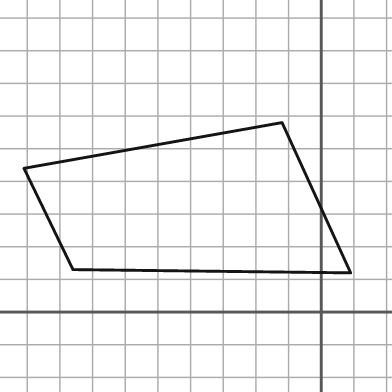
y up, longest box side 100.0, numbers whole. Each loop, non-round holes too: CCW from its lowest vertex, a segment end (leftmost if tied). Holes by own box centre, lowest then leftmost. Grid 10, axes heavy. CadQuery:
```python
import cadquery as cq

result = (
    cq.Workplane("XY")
    .moveTo(9.0, 12.0)
    .lineTo(-12.0, 58.0)
    .lineTo(-91.0, 44.0)
    .lineTo(-76.0, 13.0)
    .close()
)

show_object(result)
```